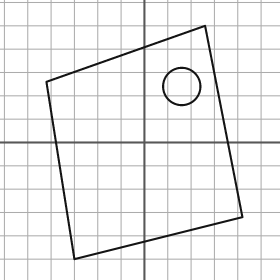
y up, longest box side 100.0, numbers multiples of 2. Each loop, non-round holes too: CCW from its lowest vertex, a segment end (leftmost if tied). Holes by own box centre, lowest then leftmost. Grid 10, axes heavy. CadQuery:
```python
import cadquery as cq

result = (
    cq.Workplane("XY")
    .moveTo(-30.0, -50.0)
    .lineTo(42.0, -32.0)
    .lineTo(26.0, 50.0)
    .lineTo(-42.0, 26.0)
    .close()
    .moveTo(16.0, 24.0)
    .circle(8.0)
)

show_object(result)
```